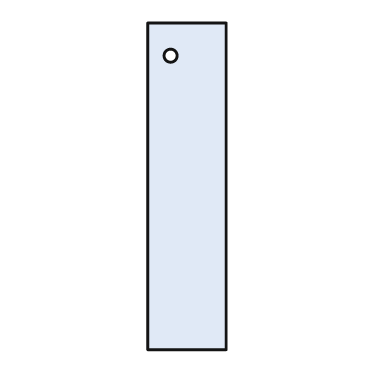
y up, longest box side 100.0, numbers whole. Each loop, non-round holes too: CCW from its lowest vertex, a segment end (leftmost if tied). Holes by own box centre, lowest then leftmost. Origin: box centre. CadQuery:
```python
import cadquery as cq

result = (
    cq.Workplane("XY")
    .moveTo(-12.0, -50.0)
    .lineTo(12.0, -50.0)
    .lineTo(12.0, 50.0)
    .lineTo(-12.0, 50.0)
    .close()
    .moveTo(-5.0, 40.0)
    .circle(2.0)
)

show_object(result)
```